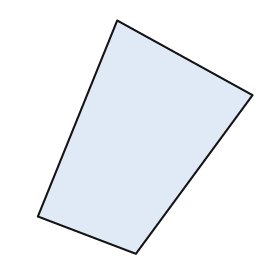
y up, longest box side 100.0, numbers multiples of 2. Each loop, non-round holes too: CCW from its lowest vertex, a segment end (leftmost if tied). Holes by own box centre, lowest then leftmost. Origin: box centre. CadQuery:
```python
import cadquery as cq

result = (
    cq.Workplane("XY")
    .moveTo(-4.0, -50.0)
    .lineTo(46.0, 18.0)
    .lineTo(-12.0, 50.0)
    .lineTo(-46.0, -34.0)
    .close()
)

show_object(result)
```